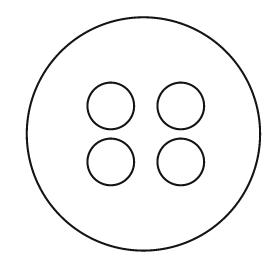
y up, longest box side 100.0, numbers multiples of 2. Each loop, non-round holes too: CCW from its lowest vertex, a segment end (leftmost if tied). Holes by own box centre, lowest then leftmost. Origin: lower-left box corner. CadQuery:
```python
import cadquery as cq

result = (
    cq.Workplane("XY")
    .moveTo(50.0, 50.0)
    .circle(50.0)
    .moveTo(36.0, 38.0)
    .circle(10.0)
    .moveTo(66.0, 38.0)
    .circle(10.0)
    .moveTo(36.0, 62.0)
    .circle(10.0)
    .moveTo(66.0, 62.0)
    .circle(10.0)
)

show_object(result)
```